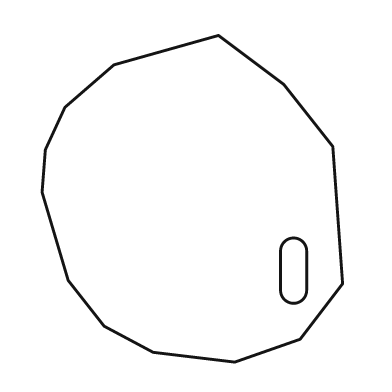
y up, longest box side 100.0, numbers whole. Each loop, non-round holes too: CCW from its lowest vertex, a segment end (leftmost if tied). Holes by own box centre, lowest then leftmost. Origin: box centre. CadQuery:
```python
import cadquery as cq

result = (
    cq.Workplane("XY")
    .moveTo(13.0, -50.0)
    .lineTo(33.0, -43.0)
    .lineTo(46.0, -26.0)
    .lineTo(43.0, 16.0)
    .lineTo(28.0, 35.0)
    .lineTo(8.0, 50.0)
    .lineTo(-24.0, 41.0)
    .lineTo(-39.0, 28.0)
    .lineTo(-45.0, 15.0)
    .lineTo(-46.0, 2.0)
    .lineTo(-38.0, -25.0)
    .lineTo(-27.0, -39.0)
    .lineTo(-12.0, -47.0)
    .close()
    .moveTo(27.0, -28.0)
    .threePointArc((31.0, -32.0), (35.0, -28.0))
    .lineTo(35.0, -16.0)
    .threePointArc((31.0, -12.0), (27.0, -16.0))
    .close()
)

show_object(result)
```